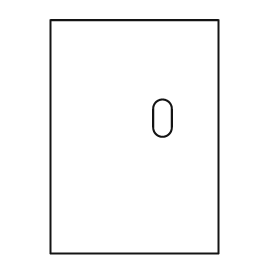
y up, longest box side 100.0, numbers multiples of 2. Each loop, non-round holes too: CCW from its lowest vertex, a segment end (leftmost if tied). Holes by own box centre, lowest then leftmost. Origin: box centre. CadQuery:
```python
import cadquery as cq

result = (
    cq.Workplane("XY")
    .moveTo(-36.0, -50.0)
    .lineTo(36.0, -50.0)
    .lineTo(36.0, 50.0)
    .lineTo(-36.0, 50.0)
    .close()
    .moveTo(8.0, 4.0)
    .threePointArc((12.0, 0.0), (16.0, 4.0))
    .lineTo(16.0, 12.0)
    .threePointArc((12.0, 16.0), (8.0, 12.0))
    .close()
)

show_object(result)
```